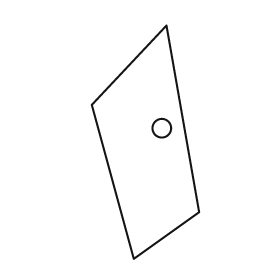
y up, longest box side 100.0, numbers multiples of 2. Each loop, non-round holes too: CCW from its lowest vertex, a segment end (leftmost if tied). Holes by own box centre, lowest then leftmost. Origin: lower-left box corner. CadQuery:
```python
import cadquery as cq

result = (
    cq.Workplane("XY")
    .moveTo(18.0, 0.0)
    .lineTo(46.0, 20.0)
    .lineTo(32.0, 100.0)
    .lineTo(0.0, 66.0)
    .close()
    .moveTo(30.0, 56.0)
    .circle(4.0)
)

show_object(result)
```